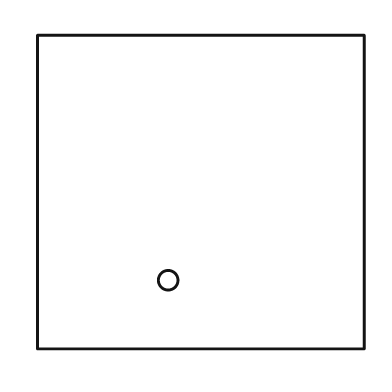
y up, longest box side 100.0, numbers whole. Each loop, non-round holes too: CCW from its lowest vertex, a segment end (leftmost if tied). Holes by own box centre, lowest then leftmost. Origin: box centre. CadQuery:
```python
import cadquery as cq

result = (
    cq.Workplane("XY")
    .moveTo(-50.0, -48.0)
    .lineTo(50.0, -48.0)
    .lineTo(50.0, 48.0)
    .lineTo(-50.0, 48.0)
    .close()
    .moveTo(-10.0, -27.0)
    .circle(3.0)
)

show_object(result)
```